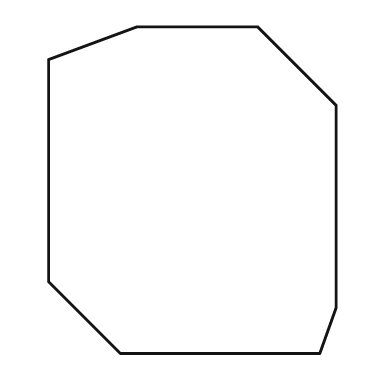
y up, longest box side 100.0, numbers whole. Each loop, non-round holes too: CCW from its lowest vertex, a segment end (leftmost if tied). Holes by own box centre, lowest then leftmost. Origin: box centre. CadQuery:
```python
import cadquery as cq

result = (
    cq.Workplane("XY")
    .moveTo(-22.0, -50.0)
    .lineTo(39.0, -50.0)
    .lineTo(44.0, -36.0)
    .lineTo(44.0, 26.0)
    .lineTo(20.0, 50.0)
    .lineTo(-17.0, 50.0)
    .lineTo(-44.0, 40.0)
    .lineTo(-44.0, -28.0)
    .close()
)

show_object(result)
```